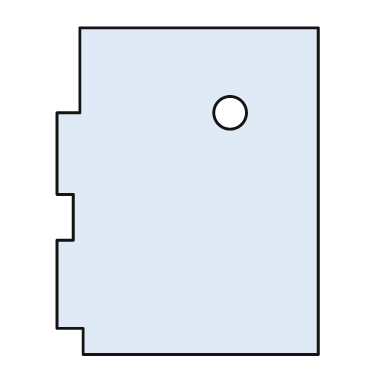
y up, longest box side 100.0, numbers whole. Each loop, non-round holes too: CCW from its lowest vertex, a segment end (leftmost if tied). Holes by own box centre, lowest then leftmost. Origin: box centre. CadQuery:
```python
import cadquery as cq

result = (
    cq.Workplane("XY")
    .moveTo(-32.0, -50.0)
    .lineTo(40.0, -50.0)
    .lineTo(40.0, 50.0)
    .lineTo(-33.0, 50.0)
    .lineTo(-33.0, 24.0)
    .lineTo(-40.0, 24.0)
    .lineTo(-40.0, -1.0)
    .lineTo(-35.0, -1.0)
    .lineTo(-35.0, -15.0)
    .lineTo(-40.0, -15.0)
    .lineTo(-40.0, -42.0)
    .lineTo(-32.0, -42.0)
    .close()
    .moveTo(13.0, 24.0)
    .circle(5.0)
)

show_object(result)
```